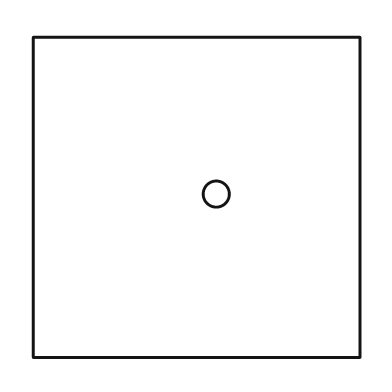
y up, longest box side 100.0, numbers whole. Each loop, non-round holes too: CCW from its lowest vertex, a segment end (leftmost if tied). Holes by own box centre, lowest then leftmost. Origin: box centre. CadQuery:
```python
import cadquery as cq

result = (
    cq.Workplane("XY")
    .moveTo(-50.0, -49.0)
    .lineTo(50.0, -49.0)
    .lineTo(50.0, 49.0)
    .lineTo(-50.0, 49.0)
    .close()
    .moveTo(6.0, 1.0)
    .circle(4.0)
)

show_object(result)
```